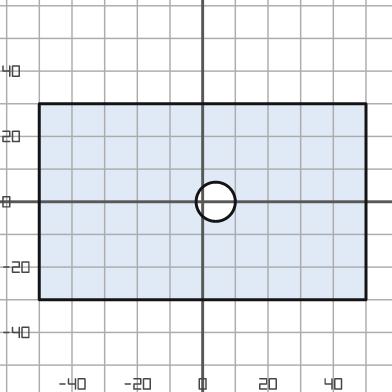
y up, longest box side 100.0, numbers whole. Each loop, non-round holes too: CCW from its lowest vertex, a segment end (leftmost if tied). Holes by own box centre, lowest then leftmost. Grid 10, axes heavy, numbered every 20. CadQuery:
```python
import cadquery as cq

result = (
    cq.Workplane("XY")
    .moveTo(-50.0, -30.0)
    .lineTo(50.0, -30.0)
    .lineTo(50.0, 30.0)
    .lineTo(-50.0, 30.0)
    .close()
    .moveTo(4.0, 0.0)
    .circle(6.0)
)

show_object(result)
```